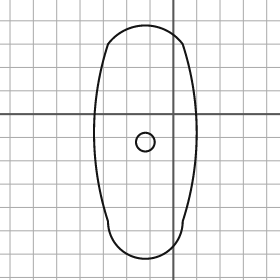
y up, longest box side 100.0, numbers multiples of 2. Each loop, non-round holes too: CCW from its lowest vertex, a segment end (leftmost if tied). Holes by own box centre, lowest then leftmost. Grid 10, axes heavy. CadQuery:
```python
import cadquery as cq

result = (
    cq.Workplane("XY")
    .moveTo(-28.0, -46.0)
    .threePointArc((-12.0, -62.0), (4.0, -46.0))
    .threePointArc((10.0, -8.0), (4.0, 30.0))
    .threePointArc((-12.0, 38.0), (-28.0, 30.0))
    .threePointArc((-34.0, -8.0), (-28.0, -46.0))
    .close()
    .moveTo(-12.0, -12.0)
    .circle(4.0)
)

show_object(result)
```